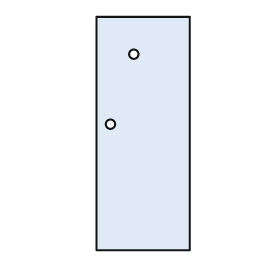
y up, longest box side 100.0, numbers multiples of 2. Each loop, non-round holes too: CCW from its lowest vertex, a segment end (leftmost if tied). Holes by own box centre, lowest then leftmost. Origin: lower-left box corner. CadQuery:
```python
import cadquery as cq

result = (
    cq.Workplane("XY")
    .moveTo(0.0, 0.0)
    .lineTo(40.0, 0.0)
    .lineTo(40.0, 100.0)
    .lineTo(0.0, 100.0)
    .close()
    .moveTo(6.0, 54.0)
    .circle(2.0)
    .moveTo(16.0, 84.0)
    .circle(2.0)
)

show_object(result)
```